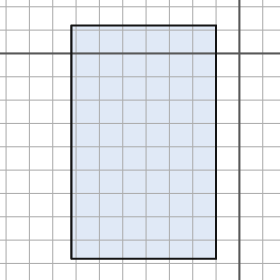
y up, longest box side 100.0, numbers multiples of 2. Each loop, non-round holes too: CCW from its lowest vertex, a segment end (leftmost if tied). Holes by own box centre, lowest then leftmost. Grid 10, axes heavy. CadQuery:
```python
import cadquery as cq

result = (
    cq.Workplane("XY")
    .moveTo(-72.0, -88.0)
    .lineTo(-10.0, -88.0)
    .lineTo(-10.0, 12.0)
    .lineTo(-72.0, 12.0)
    .close()
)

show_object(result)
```